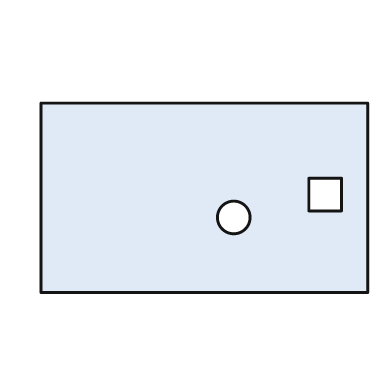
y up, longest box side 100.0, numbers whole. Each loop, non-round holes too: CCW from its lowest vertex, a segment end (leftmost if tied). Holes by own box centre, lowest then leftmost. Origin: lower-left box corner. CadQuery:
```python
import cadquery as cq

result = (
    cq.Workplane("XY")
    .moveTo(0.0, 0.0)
    .lineTo(100.0, 0.0)
    .lineTo(100.0, 58.0)
    .lineTo(0.0, 58.0)
    .close()
    .moveTo(59.0, 23.0)
    .circle(5.0)
    .moveTo(82.0, 25.0)
    .lineTo(92.0, 25.0)
    .lineTo(92.0, 35.0)
    .lineTo(82.0, 35.0)
    .close()
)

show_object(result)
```